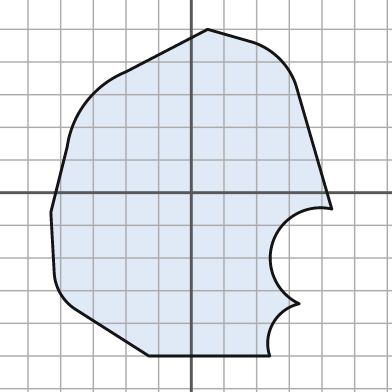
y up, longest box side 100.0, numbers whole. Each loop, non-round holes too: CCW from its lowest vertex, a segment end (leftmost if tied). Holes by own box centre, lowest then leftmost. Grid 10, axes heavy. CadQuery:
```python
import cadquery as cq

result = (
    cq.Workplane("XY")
    .moveTo(-13.0, -50.0)
    .lineTo(24.0, -50.0)
    .threePointArc((25.0, -40.0), (33.0, -34.0))
    .threePointArc((25.0, -15.0), (43.0, -5.0))
    .lineTo(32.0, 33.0)
    .threePointArc((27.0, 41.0), (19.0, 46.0))
    .lineTo(5.0, 50.0)
    .lineTo(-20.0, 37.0)
    .threePointArc((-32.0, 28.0), (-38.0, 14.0))
    .lineTo(-43.0, -6.0)
    .lineTo(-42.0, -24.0)
    .threePointArc((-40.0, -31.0), (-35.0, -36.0))
    .close()
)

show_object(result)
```